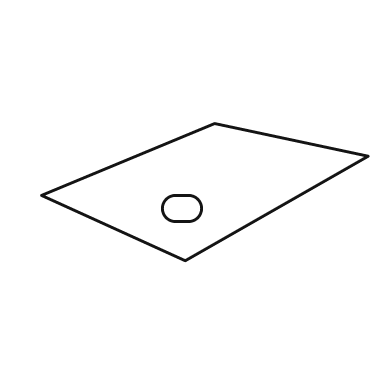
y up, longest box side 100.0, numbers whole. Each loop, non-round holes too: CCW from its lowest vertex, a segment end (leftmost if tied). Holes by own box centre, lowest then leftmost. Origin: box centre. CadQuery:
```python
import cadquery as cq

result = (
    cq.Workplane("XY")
    .moveTo(-6.0, -21.0)
    .lineTo(50.0, 11.0)
    .lineTo(3.0, 21.0)
    .lineTo(-50.0, -1.0)
    .close()
    .moveTo(-9.0, -9.0)
    .lineTo(-5.0, -9.0)
    .threePointArc((-1.0, -5.0), (-5.0, -1.0))
    .lineTo(-9.0, -1.0)
    .threePointArc((-13.0, -5.0), (-9.0, -9.0))
    .close()
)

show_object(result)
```